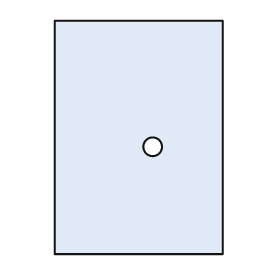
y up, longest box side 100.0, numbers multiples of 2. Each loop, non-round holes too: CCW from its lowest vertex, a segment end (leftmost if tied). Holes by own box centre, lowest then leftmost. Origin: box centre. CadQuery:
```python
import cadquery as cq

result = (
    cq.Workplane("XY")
    .moveTo(-36.0, -50.0)
    .lineTo(36.0, -50.0)
    .lineTo(36.0, 50.0)
    .lineTo(-36.0, 50.0)
    .close()
    .moveTo(6.0, -4.0)
    .circle(4.0)
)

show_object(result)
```